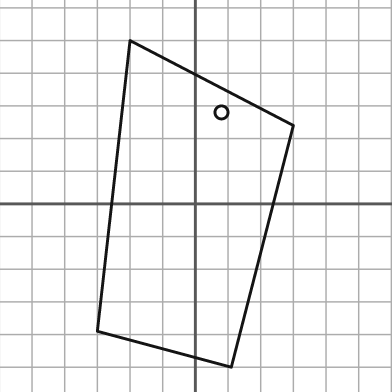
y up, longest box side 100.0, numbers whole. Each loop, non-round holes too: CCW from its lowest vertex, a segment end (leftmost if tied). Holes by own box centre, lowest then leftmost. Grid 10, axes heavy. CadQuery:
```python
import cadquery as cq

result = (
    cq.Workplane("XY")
    .moveTo(11.0, -50.0)
    .lineTo(30.0, 24.0)
    .lineTo(-20.0, 50.0)
    .lineTo(-30.0, -39.0)
    .close()
    .moveTo(8.0, 28.0)
    .circle(2.0)
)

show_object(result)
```